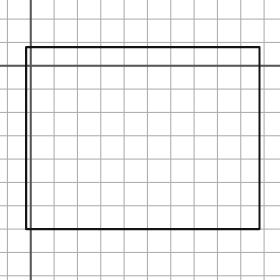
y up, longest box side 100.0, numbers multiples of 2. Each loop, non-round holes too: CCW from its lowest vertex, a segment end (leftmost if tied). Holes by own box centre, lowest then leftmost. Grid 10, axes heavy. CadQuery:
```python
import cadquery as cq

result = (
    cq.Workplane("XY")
    .moveTo(-2.0, -70.0)
    .lineTo(98.0, -70.0)
    .lineTo(98.0, 8.0)
    .lineTo(-2.0, 8.0)
    .close()
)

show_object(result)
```